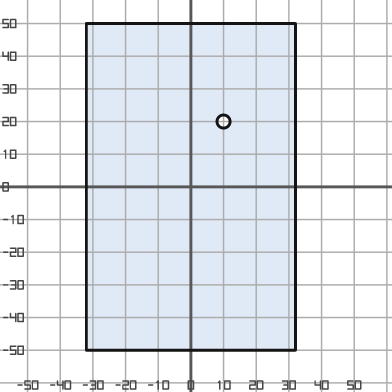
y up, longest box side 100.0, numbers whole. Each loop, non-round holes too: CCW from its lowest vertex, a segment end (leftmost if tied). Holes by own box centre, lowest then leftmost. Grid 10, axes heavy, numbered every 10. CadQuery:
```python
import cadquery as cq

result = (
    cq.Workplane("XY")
    .moveTo(-32.0, -50.0)
    .lineTo(32.0, -50.0)
    .lineTo(32.0, 50.0)
    .lineTo(-32.0, 50.0)
    .close()
    .moveTo(10.0, 20.0)
    .circle(2.0)
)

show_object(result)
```